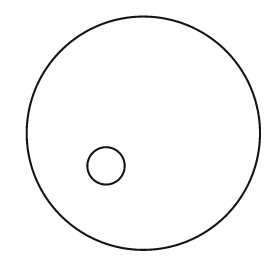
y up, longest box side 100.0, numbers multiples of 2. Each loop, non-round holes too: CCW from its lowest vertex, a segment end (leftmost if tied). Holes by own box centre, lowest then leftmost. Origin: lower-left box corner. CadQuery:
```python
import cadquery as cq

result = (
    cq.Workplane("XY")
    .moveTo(50.0, 50.0)
    .circle(50.0)
    .moveTo(34.0, 36.0)
    .circle(8.0)
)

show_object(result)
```